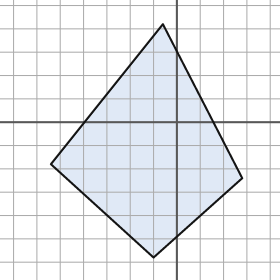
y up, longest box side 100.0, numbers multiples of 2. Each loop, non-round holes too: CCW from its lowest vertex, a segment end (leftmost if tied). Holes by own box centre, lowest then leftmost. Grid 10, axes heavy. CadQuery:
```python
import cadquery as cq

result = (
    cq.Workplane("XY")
    .moveTo(-10.0, -58.0)
    .lineTo(28.0, -24.0)
    .lineTo(-6.0, 42.0)
    .lineTo(-54.0, -18.0)
    .close()
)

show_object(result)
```